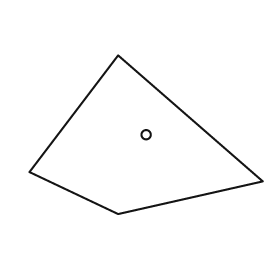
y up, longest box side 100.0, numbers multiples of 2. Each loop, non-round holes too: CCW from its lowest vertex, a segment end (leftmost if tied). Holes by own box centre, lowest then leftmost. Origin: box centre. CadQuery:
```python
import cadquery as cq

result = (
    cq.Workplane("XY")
    .moveTo(-12.0, -34.0)
    .lineTo(50.0, -20.0)
    .lineTo(-12.0, 34.0)
    .lineTo(-50.0, -16.0)
    .close()
    .moveTo(0.0, 0.0)
    .circle(2.0)
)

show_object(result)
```